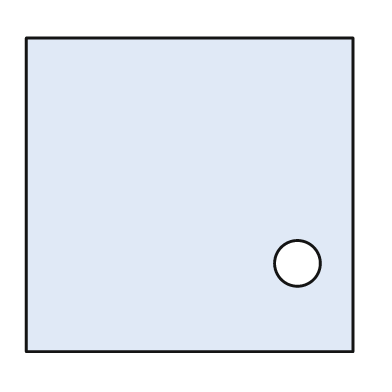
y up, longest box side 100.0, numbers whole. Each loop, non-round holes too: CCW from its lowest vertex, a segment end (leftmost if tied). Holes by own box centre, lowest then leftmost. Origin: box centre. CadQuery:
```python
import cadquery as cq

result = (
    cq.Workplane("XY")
    .moveTo(-50.0, -48.0)
    .lineTo(50.0, -48.0)
    .lineTo(50.0, 48.0)
    .lineTo(-50.0, 48.0)
    .close()
    .moveTo(33.0, -21.0)
    .circle(7.0)
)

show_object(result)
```